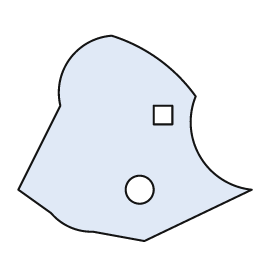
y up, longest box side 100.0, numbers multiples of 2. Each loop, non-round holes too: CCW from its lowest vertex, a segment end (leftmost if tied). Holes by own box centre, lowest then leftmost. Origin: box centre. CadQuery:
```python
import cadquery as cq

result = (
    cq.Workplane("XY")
    .moveTo(4.0, -44.0)
    .lineTo(50.0, -22.0)
    .threePointArc((28.0, -8.0), (26.0, 18.0))
    .threePointArc((10.0, 34.0), (-10.0, 44.0))
    .threePointArc((-28.0, 34.0), (-32.0, 14.0))
    .lineTo(-50.0, -22.0)
    .lineTo(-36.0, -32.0)
    .threePointArc((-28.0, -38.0), (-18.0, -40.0))
    .close()
    .moveTo(2.0, -22.0)
    .circle(6.0)
    .moveTo(8.0, 6.0)
    .lineTo(16.0, 6.0)
    .lineTo(16.0, 14.0)
    .lineTo(8.0, 14.0)
    .close()
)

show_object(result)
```